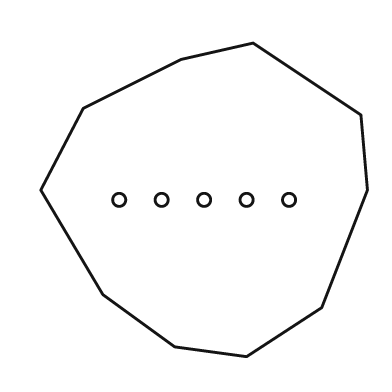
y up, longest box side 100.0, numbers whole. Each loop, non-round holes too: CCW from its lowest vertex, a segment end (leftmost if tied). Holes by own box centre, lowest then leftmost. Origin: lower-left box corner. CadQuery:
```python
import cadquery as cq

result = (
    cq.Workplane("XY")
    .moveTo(63.0, 0.0)
    .lineTo(86.0, 15.0)
    .lineTo(100.0, 51.0)
    .lineTo(98.0, 74.0)
    .lineTo(65.0, 96.0)
    .lineTo(43.0, 91.0)
    .lineTo(13.0, 76.0)
    .lineTo(0.0, 51.0)
    .lineTo(19.0, 19.0)
    .lineTo(41.0, 3.0)
    .close()
    .moveTo(24.0, 48.0)
    .circle(2.0)
    .moveTo(37.0, 48.0)
    .circle(2.0)
    .moveTo(50.0, 48.0)
    .circle(2.0)
    .moveTo(63.0, 48.0)
    .circle(2.0)
    .moveTo(76.0, 48.0)
    .circle(2.0)
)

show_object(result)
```